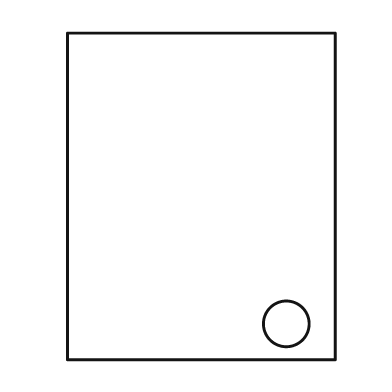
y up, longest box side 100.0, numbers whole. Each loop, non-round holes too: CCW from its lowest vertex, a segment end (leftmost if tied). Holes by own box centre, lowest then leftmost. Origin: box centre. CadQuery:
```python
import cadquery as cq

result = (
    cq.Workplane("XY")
    .moveTo(-41.0, -50.0)
    .lineTo(41.0, -50.0)
    .lineTo(41.0, 50.0)
    .lineTo(-41.0, 50.0)
    .close()
    .moveTo(26.0, -39.0)
    .circle(7.0)
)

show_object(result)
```